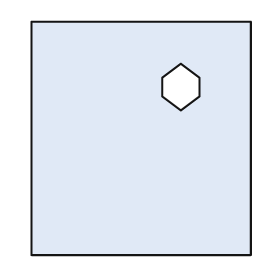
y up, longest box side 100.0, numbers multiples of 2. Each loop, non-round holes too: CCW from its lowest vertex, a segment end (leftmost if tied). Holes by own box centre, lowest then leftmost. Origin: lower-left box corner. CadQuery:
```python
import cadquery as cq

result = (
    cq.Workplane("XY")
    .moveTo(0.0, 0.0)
    .lineTo(94.0, 0.0)
    .lineTo(94.0, 100.0)
    .lineTo(0.0, 100.0)
    .close()
    .moveTo(64.0, 62.0)
    .lineTo(72.0, 68.0)
    .lineTo(72.0, 76.0)
    .lineTo(64.0, 82.0)
    .lineTo(56.0, 76.0)
    .lineTo(56.0, 68.0)
    .close()
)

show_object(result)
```